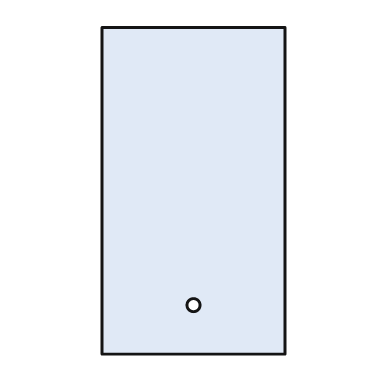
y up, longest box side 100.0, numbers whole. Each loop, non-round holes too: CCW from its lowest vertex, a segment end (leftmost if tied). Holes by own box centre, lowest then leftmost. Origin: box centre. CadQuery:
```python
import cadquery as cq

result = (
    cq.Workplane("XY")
    .moveTo(-28.0, -50.0)
    .lineTo(28.0, -50.0)
    .lineTo(28.0, 50.0)
    .lineTo(-28.0, 50.0)
    .close()
    .moveTo(0.0, -35.0)
    .circle(2.0)
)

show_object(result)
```